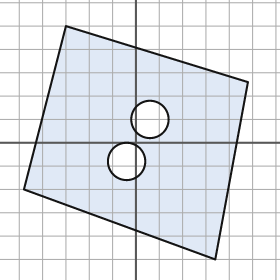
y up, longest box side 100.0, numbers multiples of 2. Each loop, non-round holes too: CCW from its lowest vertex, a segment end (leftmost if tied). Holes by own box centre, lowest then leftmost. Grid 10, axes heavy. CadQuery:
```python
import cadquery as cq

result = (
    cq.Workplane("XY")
    .moveTo(34.0, -50.0)
    .lineTo(48.0, 26.0)
    .lineTo(-30.0, 50.0)
    .lineTo(-48.0, -20.0)
    .close()
    .moveTo(-4.0, -8.0)
    .circle(8.0)
    .moveTo(6.0, 10.0)
    .circle(8.0)
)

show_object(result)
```